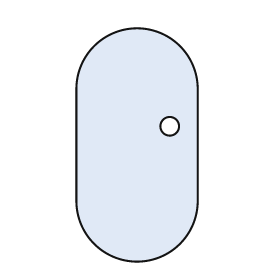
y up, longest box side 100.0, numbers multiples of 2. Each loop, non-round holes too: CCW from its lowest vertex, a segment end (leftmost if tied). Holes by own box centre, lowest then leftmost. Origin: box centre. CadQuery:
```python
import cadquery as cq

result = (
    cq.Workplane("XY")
    .moveTo(-26.0, -24.0)
    .threePointArc((0.0, -50.0), (26.0, -24.0))
    .lineTo(26.0, 24.0)
    .threePointArc((0.0, 50.0), (-26.0, 24.0))
    .close()
    .moveTo(14.0, 8.0)
    .circle(4.0)
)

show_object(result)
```